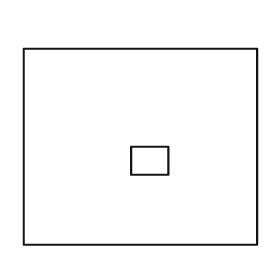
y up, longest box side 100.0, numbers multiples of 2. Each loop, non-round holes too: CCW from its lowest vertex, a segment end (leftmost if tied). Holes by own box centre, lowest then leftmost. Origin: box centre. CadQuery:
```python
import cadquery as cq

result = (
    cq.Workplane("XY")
    .moveTo(-50.0, -42.0)
    .lineTo(50.0, -42.0)
    .lineTo(50.0, 42.0)
    .lineTo(-50.0, 42.0)
    .close()
    .moveTo(-4.0, -12.0)
    .lineTo(12.0, -12.0)
    .lineTo(12.0, 0.0)
    .lineTo(-4.0, 0.0)
    .close()
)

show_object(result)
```